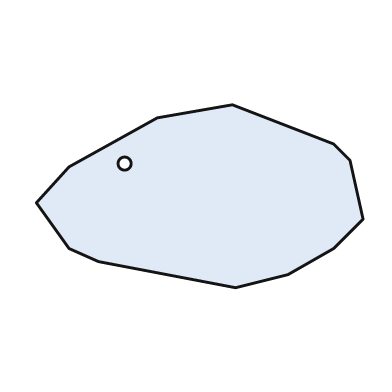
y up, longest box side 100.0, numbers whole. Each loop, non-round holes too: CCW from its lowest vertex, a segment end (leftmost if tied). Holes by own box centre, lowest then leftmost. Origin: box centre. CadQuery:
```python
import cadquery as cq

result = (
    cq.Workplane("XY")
    .moveTo(11.0, -28.0)
    .lineTo(27.0, -24.0)
    .lineTo(41.0, -16.0)
    .lineTo(50.0, -7.0)
    .lineTo(46.0, 11.0)
    .lineTo(41.0, 16.0)
    .lineTo(10.0, 28.0)
    .lineTo(-13.0, 24.0)
    .lineTo(-40.0, 9.0)
    .lineTo(-50.0, -2.0)
    .lineTo(-40.0, -16.0)
    .lineTo(-31.0, -20.0)
    .close()
    .moveTo(-23.0, 10.0)
    .circle(2.0)
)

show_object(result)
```